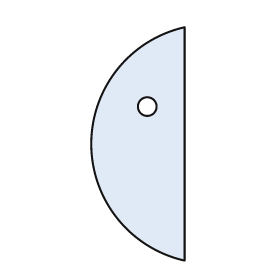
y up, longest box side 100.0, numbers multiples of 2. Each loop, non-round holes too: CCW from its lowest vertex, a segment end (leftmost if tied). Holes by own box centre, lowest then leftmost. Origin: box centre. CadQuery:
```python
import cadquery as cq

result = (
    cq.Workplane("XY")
    .moveTo(20.0, -50.0)
    .lineTo(20.0, 50.0)
    .threePointArc((-20.0, 0.0), (20.0, -50.0))
    .close()
    .moveTo(4.0, 16.0)
    .circle(4.0)
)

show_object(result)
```